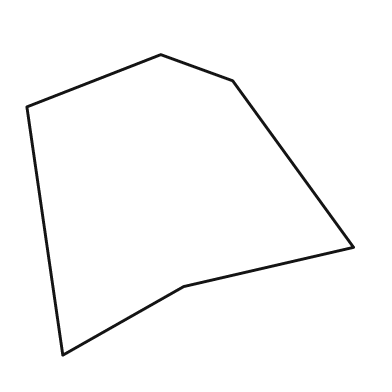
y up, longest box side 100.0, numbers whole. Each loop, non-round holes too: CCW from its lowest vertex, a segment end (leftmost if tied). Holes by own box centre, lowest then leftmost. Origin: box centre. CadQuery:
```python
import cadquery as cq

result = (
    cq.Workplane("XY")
    .moveTo(-39.0, -46.0)
    .lineTo(-2.0, -25.0)
    .lineTo(50.0, -13.0)
    .lineTo(13.0, 38.0)
    .lineTo(-9.0, 46.0)
    .lineTo(-50.0, 30.0)
    .close()
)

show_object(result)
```